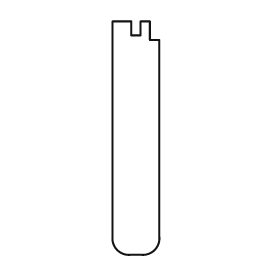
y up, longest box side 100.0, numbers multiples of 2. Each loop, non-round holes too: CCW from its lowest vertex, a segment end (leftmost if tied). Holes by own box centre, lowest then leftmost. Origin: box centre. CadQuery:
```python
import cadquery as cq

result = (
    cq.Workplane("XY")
    .moveTo(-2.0, -50.0)
    .lineTo(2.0, -50.0)
    .threePointArc((8.0, -48.0), (10.0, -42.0))
    .lineTo(10.0, 42.0)
    .lineTo(6.0, 42.0)
    .lineTo(6.0, 50.0)
    .lineTo(2.0, 50.0)
    .lineTo(2.0, 44.0)
    .lineTo(-2.0, 44.0)
    .lineTo(-2.0, 50.0)
    .lineTo(-10.0, 50.0)
    .lineTo(-10.0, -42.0)
    .threePointArc((-8.0, -48.0), (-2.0, -50.0))
    .close()
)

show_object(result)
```